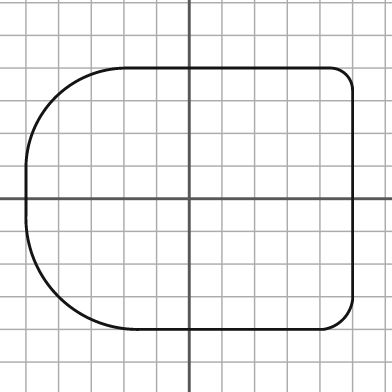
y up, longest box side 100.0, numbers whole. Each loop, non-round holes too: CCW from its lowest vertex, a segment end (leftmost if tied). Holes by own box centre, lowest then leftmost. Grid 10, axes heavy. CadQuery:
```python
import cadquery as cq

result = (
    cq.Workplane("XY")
    .moveTo(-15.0, -40.0)
    .lineTo(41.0, -40.0)
    .threePointArc((47.0, -37.0), (50.0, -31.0))
    .lineTo(50.0, 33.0)
    .threePointArc((48.0, 38.0), (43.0, 40.0))
    .lineTo(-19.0, 40.0)
    .threePointArc((-41.0, 31.0), (-50.0, 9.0))
    .lineTo(-50.0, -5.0)
    .threePointArc((-40.0, -30.0), (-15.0, -40.0))
    .close()
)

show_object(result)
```